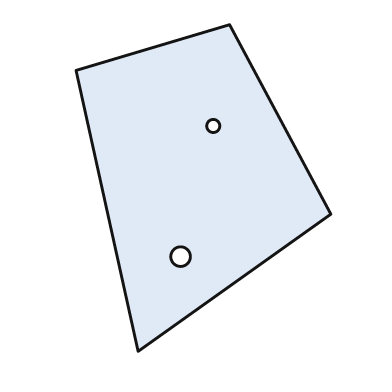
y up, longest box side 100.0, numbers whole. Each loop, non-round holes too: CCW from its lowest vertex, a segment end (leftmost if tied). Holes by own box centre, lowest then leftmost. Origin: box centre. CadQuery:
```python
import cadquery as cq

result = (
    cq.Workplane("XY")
    .moveTo(-20.0, -50.0)
    .lineTo(39.0, -8.0)
    .lineTo(8.0, 50.0)
    .lineTo(-39.0, 36.0)
    .close()
    .moveTo(-7.0, -21.0)
    .circle(3.0)
    .moveTo(3.0, 19.0)
    .circle(2.0)
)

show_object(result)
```